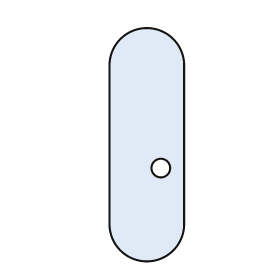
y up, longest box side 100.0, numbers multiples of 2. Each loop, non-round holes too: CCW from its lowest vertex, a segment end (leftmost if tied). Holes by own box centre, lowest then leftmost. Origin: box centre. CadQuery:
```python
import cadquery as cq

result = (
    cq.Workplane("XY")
    .moveTo(-16.0, -34.0)
    .threePointArc((0.0, -50.0), (16.0, -34.0))
    .lineTo(16.0, 34.0)
    .threePointArc((0.0, 50.0), (-16.0, 34.0))
    .close()
    .moveTo(6.0, -10.0)
    .circle(4.0)
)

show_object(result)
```